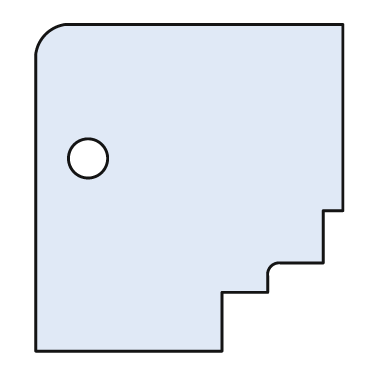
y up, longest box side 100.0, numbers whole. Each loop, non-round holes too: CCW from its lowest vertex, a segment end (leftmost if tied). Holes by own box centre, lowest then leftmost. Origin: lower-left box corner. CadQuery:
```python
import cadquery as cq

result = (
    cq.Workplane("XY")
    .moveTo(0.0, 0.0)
    .lineTo(57.0, 0.0)
    .lineTo(57.0, 18.0)
    .lineTo(71.0, 18.0)
    .lineTo(71.0, 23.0)
    .threePointArc((72.0, 26.0), (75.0, 27.0))
    .lineTo(88.0, 27.0)
    .lineTo(88.0, 43.0)
    .lineTo(94.0, 43.0)
    .lineTo(94.0, 100.0)
    .lineTo(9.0, 100.0)
    .threePointArc((3.0, 97.0), (0.0, 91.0))
    .close()
    .moveTo(16.0, 59.0)
    .circle(6.0)
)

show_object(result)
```